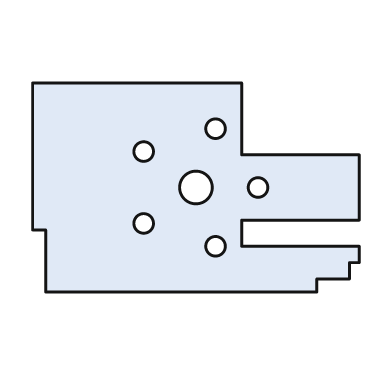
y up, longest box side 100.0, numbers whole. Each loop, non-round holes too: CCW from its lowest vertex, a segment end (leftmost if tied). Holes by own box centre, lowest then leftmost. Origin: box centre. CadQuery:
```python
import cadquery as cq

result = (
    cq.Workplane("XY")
    .moveTo(-46.0, -32.0)
    .lineTo(37.0, -32.0)
    .lineTo(37.0, -28.0)
    .lineTo(47.0, -28.0)
    .lineTo(47.0, -23.0)
    .lineTo(50.0, -23.0)
    .lineTo(50.0, -18.0)
    .lineTo(14.0, -18.0)
    .lineTo(14.0, -10.0)
    .lineTo(50.0, -10.0)
    .lineTo(50.0, 10.0)
    .lineTo(14.0, 10.0)
    .lineTo(14.0, 32.0)
    .lineTo(-50.0, 32.0)
    .lineTo(-50.0, -13.0)
    .lineTo(-46.0, -13.0)
    .close()
    .moveTo(6.0, -18.0)
    .circle(3.0)
    .moveTo(-16.0, -11.0)
    .circle(3.0)
    .moveTo(0.0, 0.0)
    .circle(5.0)
    .moveTo(19.0, 0.0)
    .circle(3.0)
    .moveTo(-16.0, 11.0)
    .circle(3.0)
    .moveTo(6.0, 18.0)
    .circle(3.0)
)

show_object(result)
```